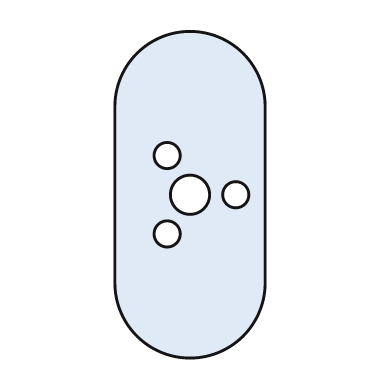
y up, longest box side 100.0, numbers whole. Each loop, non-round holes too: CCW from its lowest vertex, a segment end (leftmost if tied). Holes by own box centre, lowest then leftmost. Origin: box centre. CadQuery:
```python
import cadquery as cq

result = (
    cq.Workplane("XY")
    .moveTo(-23.0, -27.0)
    .threePointArc((0.0, -50.0), (23.0, -27.0))
    .lineTo(23.0, 27.0)
    .threePointArc((0.0, 50.0), (-23.0, 27.0))
    .close()
    .moveTo(-7.0, -12.0)
    .circle(4.0)
    .moveTo(0.0, 0.0)
    .circle(6.0)
    .moveTo(14.0, 0.0)
    .circle(4.0)
    .moveTo(-7.0, 12.0)
    .circle(4.0)
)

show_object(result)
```